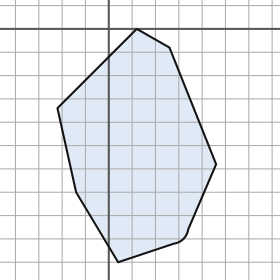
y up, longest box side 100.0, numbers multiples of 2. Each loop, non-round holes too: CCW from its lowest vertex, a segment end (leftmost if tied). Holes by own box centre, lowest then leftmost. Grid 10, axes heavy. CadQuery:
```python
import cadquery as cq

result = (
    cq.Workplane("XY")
    .moveTo(4.0, -100.0)
    .lineTo(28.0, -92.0)
    .threePointArc((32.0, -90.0), (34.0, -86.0))
    .lineTo(46.0, -58.0)
    .lineTo(26.0, -8.0)
    .lineTo(12.0, 0.0)
    .lineTo(-22.0, -34.0)
    .lineTo(-14.0, -70.0)
    .close()
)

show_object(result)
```